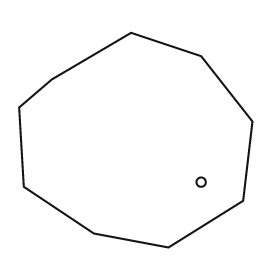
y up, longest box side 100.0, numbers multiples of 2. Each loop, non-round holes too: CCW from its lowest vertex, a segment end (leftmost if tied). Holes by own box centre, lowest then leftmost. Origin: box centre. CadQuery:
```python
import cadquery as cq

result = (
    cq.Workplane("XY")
    .moveTo(14.0, -46.0)
    .lineTo(46.0, -26.0)
    .lineTo(50.0, 8.0)
    .lineTo(28.0, 36.0)
    .lineTo(-2.0, 46.0)
    .lineTo(-36.0, 26.0)
    .lineTo(-50.0, 14.0)
    .lineTo(-48.0, -20.0)
    .lineTo(-18.0, -40.0)
    .close()
    .moveTo(28.0, -18.0)
    .circle(2.0)
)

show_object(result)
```